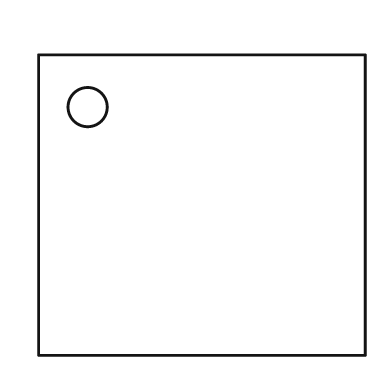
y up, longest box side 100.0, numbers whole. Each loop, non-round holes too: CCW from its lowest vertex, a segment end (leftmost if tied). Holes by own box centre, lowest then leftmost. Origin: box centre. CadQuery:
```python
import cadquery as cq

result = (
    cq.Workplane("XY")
    .moveTo(-50.0, -46.0)
    .lineTo(50.0, -46.0)
    .lineTo(50.0, 46.0)
    .lineTo(-50.0, 46.0)
    .close()
    .moveTo(-35.0, 30.0)
    .circle(6.0)
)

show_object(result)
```